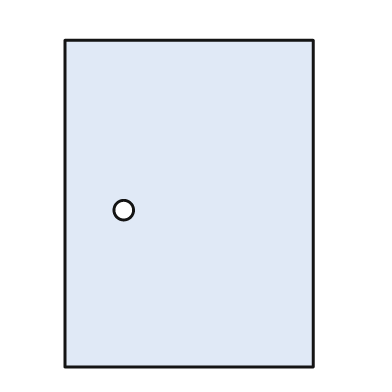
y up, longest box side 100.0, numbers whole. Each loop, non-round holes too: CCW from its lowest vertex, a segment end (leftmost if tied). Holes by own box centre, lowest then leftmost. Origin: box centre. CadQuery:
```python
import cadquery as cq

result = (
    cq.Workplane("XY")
    .moveTo(-38.0, -50.0)
    .lineTo(38.0, -50.0)
    .lineTo(38.0, 50.0)
    .lineTo(-38.0, 50.0)
    .close()
    .moveTo(-20.0, -2.0)
    .circle(3.0)
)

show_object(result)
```